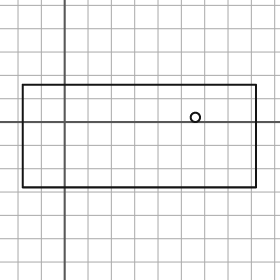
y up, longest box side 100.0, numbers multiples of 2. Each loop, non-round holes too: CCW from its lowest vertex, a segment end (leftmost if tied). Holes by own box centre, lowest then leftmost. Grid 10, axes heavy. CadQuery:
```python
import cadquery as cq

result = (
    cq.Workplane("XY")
    .moveTo(-18.0, -28.0)
    .lineTo(82.0, -28.0)
    .lineTo(82.0, 16.0)
    .lineTo(-18.0, 16.0)
    .close()
    .moveTo(56.0, 2.0)
    .circle(2.0)
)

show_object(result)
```